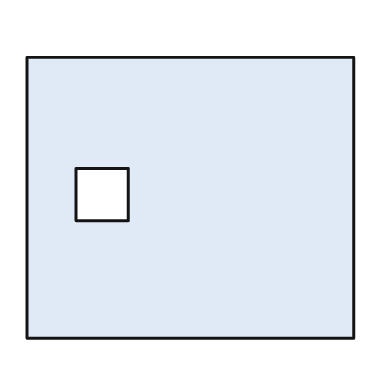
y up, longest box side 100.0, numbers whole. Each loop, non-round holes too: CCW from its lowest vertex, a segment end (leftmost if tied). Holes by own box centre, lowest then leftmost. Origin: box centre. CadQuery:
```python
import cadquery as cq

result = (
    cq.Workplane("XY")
    .moveTo(-50.0, -43.0)
    .lineTo(50.0, -43.0)
    .lineTo(50.0, 43.0)
    .lineTo(-50.0, 43.0)
    .close()
    .moveTo(-35.0, -7.0)
    .lineTo(-19.0, -7.0)
    .lineTo(-19.0, 9.0)
    .lineTo(-35.0, 9.0)
    .close()
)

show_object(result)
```